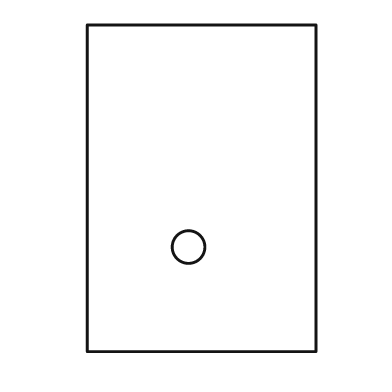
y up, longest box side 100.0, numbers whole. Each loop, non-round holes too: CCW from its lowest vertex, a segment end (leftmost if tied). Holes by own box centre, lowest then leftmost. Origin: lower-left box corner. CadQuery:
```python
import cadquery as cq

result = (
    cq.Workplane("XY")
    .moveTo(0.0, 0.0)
    .lineTo(70.0, 0.0)
    .lineTo(70.0, 100.0)
    .lineTo(0.0, 100.0)
    .close()
    .moveTo(31.0, 32.0)
    .circle(5.0)
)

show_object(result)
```